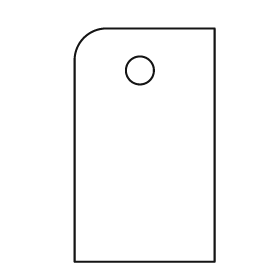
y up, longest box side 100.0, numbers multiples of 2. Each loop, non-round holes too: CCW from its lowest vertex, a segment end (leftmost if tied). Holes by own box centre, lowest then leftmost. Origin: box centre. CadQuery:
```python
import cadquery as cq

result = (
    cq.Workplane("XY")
    .moveTo(-30.0, -50.0)
    .lineTo(30.0, -50.0)
    .lineTo(30.0, 50.0)
    .lineTo(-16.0, 50.0)
    .threePointArc((-26.0, 46.0), (-30.0, 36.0))
    .close()
    .moveTo(-2.0, 32.0)
    .circle(6.0)
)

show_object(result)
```